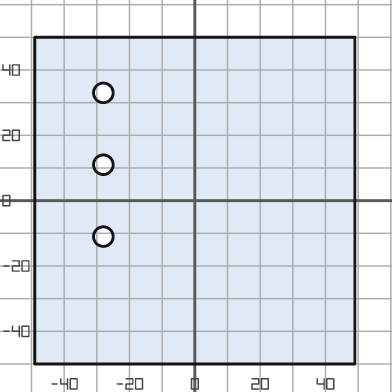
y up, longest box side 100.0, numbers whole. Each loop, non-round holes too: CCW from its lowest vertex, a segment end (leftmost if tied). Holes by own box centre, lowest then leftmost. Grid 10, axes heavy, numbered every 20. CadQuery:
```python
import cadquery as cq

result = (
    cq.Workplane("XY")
    .moveTo(-49.0, -50.0)
    .lineTo(49.0, -50.0)
    .lineTo(49.0, 50.0)
    .lineTo(-49.0, 50.0)
    .close()
    .moveTo(-28.0, -11.0)
    .circle(3.0)
    .moveTo(-28.0, 11.0)
    .circle(3.0)
    .moveTo(-28.0, 33.0)
    .circle(3.0)
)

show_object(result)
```